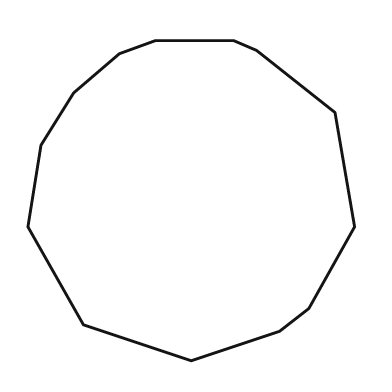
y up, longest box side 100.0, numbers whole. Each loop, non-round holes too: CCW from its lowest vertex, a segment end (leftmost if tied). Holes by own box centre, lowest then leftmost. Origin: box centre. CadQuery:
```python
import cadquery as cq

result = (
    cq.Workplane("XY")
    .moveTo(0.0, -49.0)
    .lineTo(27.0, -40.0)
    .lineTo(36.0, -33.0)
    .lineTo(50.0, -8.0)
    .lineTo(44.0, 27.0)
    .lineTo(20.0, 46.0)
    .lineTo(13.0, 49.0)
    .lineTo(-11.0, 49.0)
    .lineTo(-22.0, 45.0)
    .lineTo(-36.0, 33.0)
    .lineTo(-46.0, 17.0)
    .lineTo(-50.0, -8.0)
    .lineTo(-33.0, -38.0)
    .close()
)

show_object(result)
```